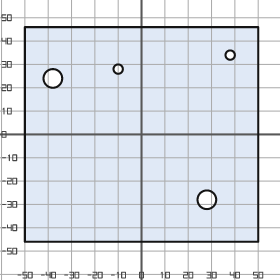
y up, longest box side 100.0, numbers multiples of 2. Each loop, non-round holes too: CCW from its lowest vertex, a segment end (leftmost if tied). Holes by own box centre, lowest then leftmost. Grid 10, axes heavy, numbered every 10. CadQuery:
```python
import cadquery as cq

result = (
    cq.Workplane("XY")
    .moveTo(-50.0, -46.0)
    .lineTo(50.0, -46.0)
    .lineTo(50.0, 46.0)
    .lineTo(-50.0, 46.0)
    .close()
    .moveTo(28.0, -28.0)
    .circle(4.0)
    .moveTo(-38.0, 24.0)
    .circle(4.0)
    .moveTo(-10.0, 28.0)
    .circle(2.0)
    .moveTo(38.0, 34.0)
    .circle(2.0)
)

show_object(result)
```